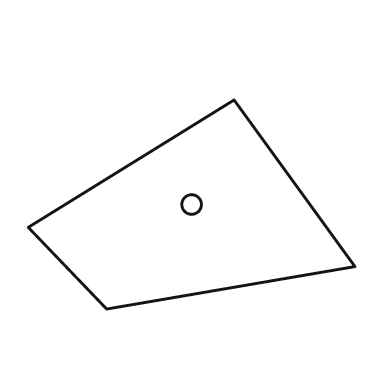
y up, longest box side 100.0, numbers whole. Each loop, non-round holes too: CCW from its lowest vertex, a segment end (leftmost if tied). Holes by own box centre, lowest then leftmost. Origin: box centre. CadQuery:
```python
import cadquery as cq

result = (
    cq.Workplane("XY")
    .moveTo(-26.0, -32.0)
    .lineTo(50.0, -19.0)
    .lineTo(13.0, 32.0)
    .lineTo(-50.0, -7.0)
    .close()
    .moveTo(0.0, 0.0)
    .circle(3.0)
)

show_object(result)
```